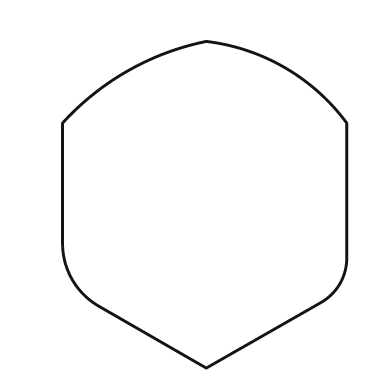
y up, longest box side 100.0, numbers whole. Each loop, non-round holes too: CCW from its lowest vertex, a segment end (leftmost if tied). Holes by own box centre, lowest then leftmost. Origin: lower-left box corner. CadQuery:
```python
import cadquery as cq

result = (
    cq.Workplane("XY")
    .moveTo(44.0, 0.0)
    .lineTo(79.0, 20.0)
    .threePointArc((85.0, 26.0), (87.0, 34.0))
    .lineTo(87.0, 75.0)
    .threePointArc((68.0, 92.0), (44.0, 100.0))
    .threePointArc((20.0, 91.0), (0.0, 75.0))
    .lineTo(0.0, 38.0)
    .threePointArc((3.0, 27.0), (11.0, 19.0))
    .close()
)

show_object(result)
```